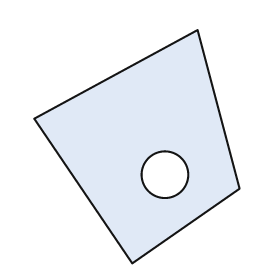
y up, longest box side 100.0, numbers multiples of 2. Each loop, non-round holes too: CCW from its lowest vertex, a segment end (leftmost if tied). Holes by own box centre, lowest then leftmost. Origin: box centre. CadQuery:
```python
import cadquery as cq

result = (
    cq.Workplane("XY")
    .moveTo(-2.0, -50.0)
    .lineTo(44.0, -18.0)
    .lineTo(26.0, 50.0)
    .lineTo(-44.0, 12.0)
    .close()
    .moveTo(12.0, -12.0)
    .circle(10.0)
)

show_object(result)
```